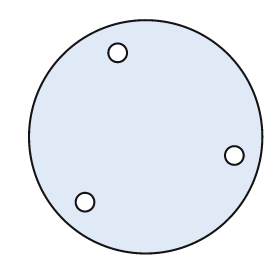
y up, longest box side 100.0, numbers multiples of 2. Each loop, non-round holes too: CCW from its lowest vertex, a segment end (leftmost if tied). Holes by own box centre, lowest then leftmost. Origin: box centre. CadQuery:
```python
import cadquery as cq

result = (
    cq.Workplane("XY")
    .moveTo(0.0, 0.0)
    .circle(50.0)
    .moveTo(-26.0, -28.0)
    .circle(4.0)
    .moveTo(38.0, -8.0)
    .circle(4.0)
    .moveTo(-12.0, 36.0)
    .circle(4.0)
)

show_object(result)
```